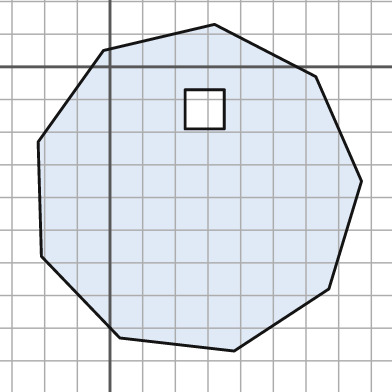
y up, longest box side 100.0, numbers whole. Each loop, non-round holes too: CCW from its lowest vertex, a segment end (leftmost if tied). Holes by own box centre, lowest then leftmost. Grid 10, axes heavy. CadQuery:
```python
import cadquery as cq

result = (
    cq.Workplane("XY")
    .moveTo(38.0, -87.0)
    .lineTo(67.0, -68.0)
    .lineTo(77.0, -35.0)
    .lineTo(63.0, -3.0)
    .lineTo(32.0, 13.0)
    .lineTo(-2.0, 5.0)
    .lineTo(-22.0, -23.0)
    .lineTo(-21.0, -58.0)
    .lineTo(3.0, -83.0)
    .close()
    .moveTo(23.0, -19.0)
    .lineTo(35.0, -19.0)
    .lineTo(35.0, -7.0)
    .lineTo(23.0, -7.0)
    .close()
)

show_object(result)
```